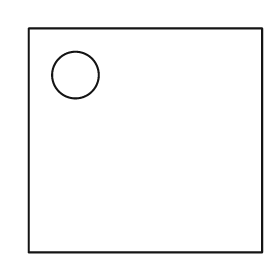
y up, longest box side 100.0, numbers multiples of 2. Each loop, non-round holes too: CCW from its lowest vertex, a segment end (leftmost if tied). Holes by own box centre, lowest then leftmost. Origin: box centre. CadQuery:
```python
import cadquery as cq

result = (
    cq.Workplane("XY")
    .moveTo(-50.0, -48.0)
    .lineTo(50.0, -48.0)
    .lineTo(50.0, 48.0)
    .lineTo(-50.0, 48.0)
    .close()
    .moveTo(-30.0, 28.0)
    .circle(10.0)
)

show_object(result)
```